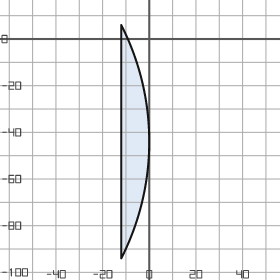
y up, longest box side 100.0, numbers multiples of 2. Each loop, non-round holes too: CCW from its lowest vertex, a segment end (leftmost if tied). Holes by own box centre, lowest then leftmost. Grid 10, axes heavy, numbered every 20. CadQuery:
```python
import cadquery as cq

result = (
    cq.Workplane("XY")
    .moveTo(-12.0, -94.0)
    .threePointArc((0.0, -44.0), (-12.0, 6.0))
    .close()
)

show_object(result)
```